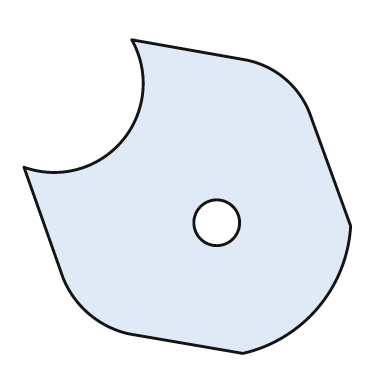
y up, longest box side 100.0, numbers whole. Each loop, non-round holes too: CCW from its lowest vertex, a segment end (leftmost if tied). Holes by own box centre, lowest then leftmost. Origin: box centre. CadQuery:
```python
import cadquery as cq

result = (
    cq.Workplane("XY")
    .moveTo(17.0, -48.0)
    .threePointArc((40.0, -34.0), (50.0, -9.0))
    .lineTo(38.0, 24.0)
    .threePointArc((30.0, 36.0), (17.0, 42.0))
    .lineTo(-17.0, 48.0)
    .threePointArc((-20.0, 17.0), (-50.0, 9.0))
    .lineTo(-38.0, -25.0)
    .threePointArc((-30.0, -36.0), (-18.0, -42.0))
    .close()
    .moveTo(9.0, -8.0)
    .circle(7.0)
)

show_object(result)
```